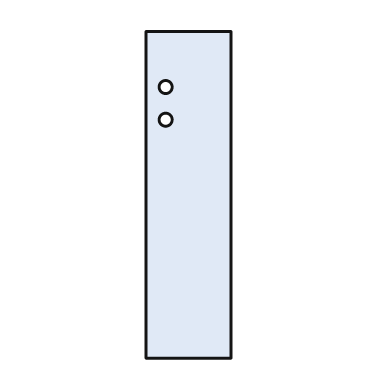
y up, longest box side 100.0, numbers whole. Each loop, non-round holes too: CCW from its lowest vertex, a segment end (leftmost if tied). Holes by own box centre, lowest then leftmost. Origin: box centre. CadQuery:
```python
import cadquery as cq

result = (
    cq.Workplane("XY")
    .moveTo(-13.0, -50.0)
    .lineTo(13.0, -50.0)
    .lineTo(13.0, 50.0)
    .lineTo(-13.0, 50.0)
    .close()
    .moveTo(-7.0, 23.0)
    .circle(2.0)
    .moveTo(-7.0, 33.0)
    .circle(2.0)
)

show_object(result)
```